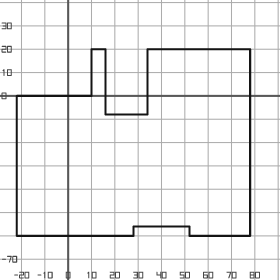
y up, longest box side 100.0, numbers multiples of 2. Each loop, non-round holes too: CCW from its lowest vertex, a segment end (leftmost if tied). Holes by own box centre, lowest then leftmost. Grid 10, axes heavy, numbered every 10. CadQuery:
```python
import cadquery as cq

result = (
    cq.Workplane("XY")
    .moveTo(-22.0, -60.0)
    .lineTo(28.0, -60.0)
    .lineTo(28.0, -56.0)
    .lineTo(52.0, -56.0)
    .lineTo(52.0, -60.0)
    .lineTo(78.0, -60.0)
    .lineTo(78.0, 20.0)
    .lineTo(34.0, 20.0)
    .lineTo(34.0, -8.0)
    .lineTo(16.0, -8.0)
    .lineTo(16.0, 20.0)
    .lineTo(10.0, 20.0)
    .lineTo(10.0, 0.0)
    .lineTo(-22.0, 0.0)
    .close()
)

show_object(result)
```